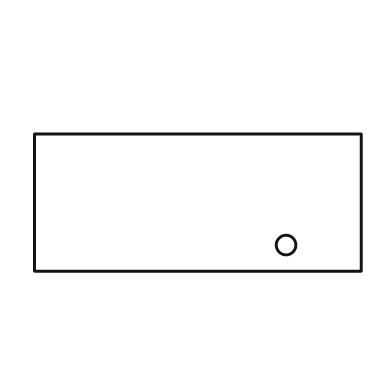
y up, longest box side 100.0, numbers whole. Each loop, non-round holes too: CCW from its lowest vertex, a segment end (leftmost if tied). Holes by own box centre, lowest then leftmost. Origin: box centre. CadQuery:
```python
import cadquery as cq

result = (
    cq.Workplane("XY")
    .moveTo(-50.0, -21.0)
    .lineTo(50.0, -21.0)
    .lineTo(50.0, 21.0)
    .lineTo(-50.0, 21.0)
    .close()
    .moveTo(27.0, -13.0)
    .circle(3.0)
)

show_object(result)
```